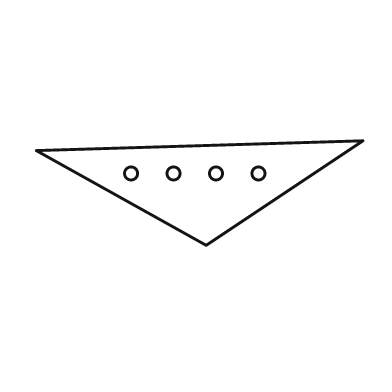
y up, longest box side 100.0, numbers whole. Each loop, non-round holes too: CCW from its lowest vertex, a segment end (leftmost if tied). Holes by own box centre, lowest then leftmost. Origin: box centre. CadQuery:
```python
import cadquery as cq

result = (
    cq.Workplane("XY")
    .moveTo(2.0, -16.0)
    .lineTo(50.0, 16.0)
    .lineTo(-50.0, 13.0)
    .close()
    .moveTo(-21.0, 6.0)
    .circle(2.0)
    .moveTo(-8.0, 6.0)
    .circle(2.0)
    .moveTo(5.0, 6.0)
    .circle(2.0)
    .moveTo(18.0, 6.0)
    .circle(2.0)
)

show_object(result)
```